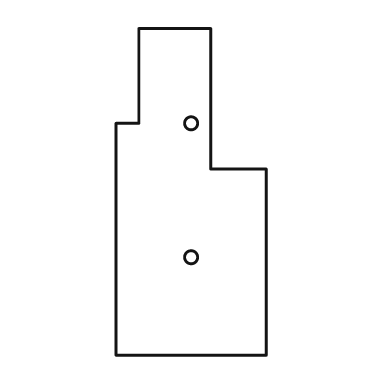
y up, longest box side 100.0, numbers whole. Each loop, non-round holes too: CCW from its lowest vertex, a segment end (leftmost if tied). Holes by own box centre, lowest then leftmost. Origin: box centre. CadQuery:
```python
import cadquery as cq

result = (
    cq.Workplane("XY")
    .moveTo(-23.0, -50.0)
    .lineTo(23.0, -50.0)
    .lineTo(23.0, 7.0)
    .lineTo(6.0, 7.0)
    .lineTo(6.0, 50.0)
    .lineTo(-16.0, 50.0)
    .lineTo(-16.0, 21.0)
    .lineTo(-23.0, 21.0)
    .close()
    .moveTo(0.0, -20.0)
    .circle(2.0)
    .moveTo(0.0, 21.0)
    .circle(2.0)
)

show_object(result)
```